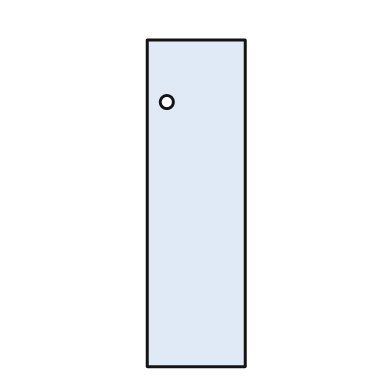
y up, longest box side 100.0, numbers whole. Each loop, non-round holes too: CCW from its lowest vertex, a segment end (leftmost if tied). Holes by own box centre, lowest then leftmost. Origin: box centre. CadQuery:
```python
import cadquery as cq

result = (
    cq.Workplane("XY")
    .moveTo(-15.0, -50.0)
    .lineTo(15.0, -50.0)
    .lineTo(15.0, 50.0)
    .lineTo(-15.0, 50.0)
    .close()
    .moveTo(-9.0, 31.0)
    .circle(2.0)
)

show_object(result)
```